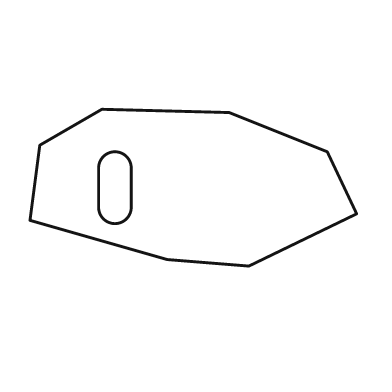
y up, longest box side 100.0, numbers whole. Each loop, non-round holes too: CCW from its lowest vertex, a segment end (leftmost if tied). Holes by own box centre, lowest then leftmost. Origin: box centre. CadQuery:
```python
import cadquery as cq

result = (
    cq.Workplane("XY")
    .moveTo(17.0, -24.0)
    .lineTo(50.0, -8.0)
    .lineTo(41.0, 11.0)
    .lineTo(11.0, 23.0)
    .lineTo(-28.0, 24.0)
    .lineTo(-47.0, 13.0)
    .lineTo(-50.0, -10.0)
    .lineTo(-8.0, -22.0)
    .close()
    .moveTo(-29.0, -6.0)
    .threePointArc((-24.0, -11.0), (-19.0, -6.0))
    .lineTo(-19.0, 6.0)
    .threePointArc((-24.0, 11.0), (-29.0, 6.0))
    .close()
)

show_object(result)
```